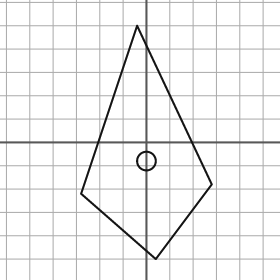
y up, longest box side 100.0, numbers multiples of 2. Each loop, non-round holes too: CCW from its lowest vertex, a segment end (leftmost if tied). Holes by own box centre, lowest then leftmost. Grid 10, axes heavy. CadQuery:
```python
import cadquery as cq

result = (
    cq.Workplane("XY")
    .moveTo(4.0, -50.0)
    .lineTo(28.0, -18.0)
    .lineTo(-4.0, 50.0)
    .lineTo(-28.0, -22.0)
    .close()
    .moveTo(0.0, -8.0)
    .circle(4.0)
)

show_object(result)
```